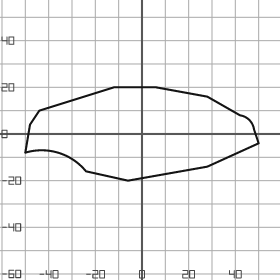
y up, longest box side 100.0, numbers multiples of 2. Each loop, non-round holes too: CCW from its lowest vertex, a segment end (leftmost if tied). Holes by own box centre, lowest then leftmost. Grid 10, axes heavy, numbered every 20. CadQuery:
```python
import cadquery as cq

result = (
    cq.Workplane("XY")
    .moveTo(-6.0, -20.0)
    .lineTo(28.0, -14.0)
    .lineTo(50.0, -4.0)
    .lineTo(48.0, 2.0)
    .threePointArc((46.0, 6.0), (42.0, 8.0))
    .lineTo(28.0, 16.0)
    .lineTo(6.0, 20.0)
    .lineTo(-12.0, 20.0)
    .lineTo(-44.0, 10.0)
    .lineTo(-48.0, 4.0)
    .lineTo(-50.0, -8.0)
    .threePointArc((-36.0, -8.0), (-24.0, -16.0))
    .close()
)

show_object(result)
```